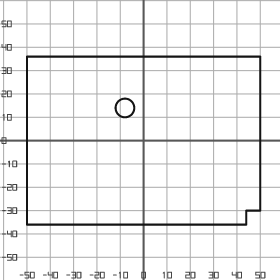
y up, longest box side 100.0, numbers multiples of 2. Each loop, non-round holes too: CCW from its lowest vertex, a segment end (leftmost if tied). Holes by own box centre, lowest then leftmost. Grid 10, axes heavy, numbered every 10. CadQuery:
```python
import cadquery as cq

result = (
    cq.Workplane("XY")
    .moveTo(-50.0, -36.0)
    .lineTo(44.0, -36.0)
    .lineTo(44.0, -30.0)
    .lineTo(50.0, -30.0)
    .lineTo(50.0, 36.0)
    .lineTo(-50.0, 36.0)
    .close()
    .moveTo(-8.0, 14.0)
    .circle(4.0)
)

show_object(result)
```